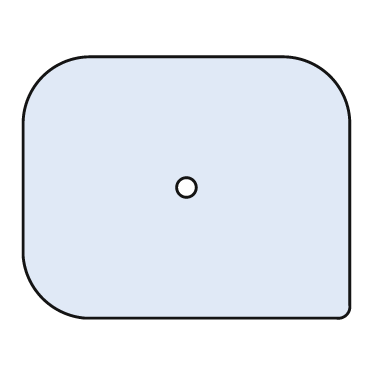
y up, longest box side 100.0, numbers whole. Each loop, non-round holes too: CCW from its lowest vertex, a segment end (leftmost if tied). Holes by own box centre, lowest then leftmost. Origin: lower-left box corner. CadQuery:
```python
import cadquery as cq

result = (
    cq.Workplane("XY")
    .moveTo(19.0, 0.0)
    .lineTo(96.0, 0.0)
    .threePointArc((99.0, 1.0), (100.0, 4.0))
    .lineTo(100.0, 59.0)
    .threePointArc((94.0, 74.0), (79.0, 80.0))
    .lineTo(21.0, 80.0)
    .threePointArc((6.0, 74.0), (0.0, 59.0))
    .lineTo(0.0, 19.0)
    .threePointArc((6.0, 6.0), (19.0, 0.0))
    .close()
    .moveTo(50.0, 40.0)
    .circle(3.0)
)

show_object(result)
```